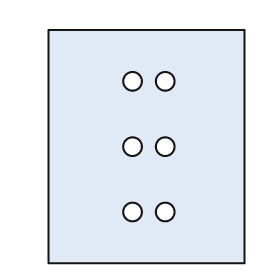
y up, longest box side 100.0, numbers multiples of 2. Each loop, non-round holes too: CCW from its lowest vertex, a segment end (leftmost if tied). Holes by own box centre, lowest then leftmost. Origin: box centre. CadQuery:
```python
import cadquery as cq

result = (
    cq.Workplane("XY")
    .moveTo(-42.0, -50.0)
    .lineTo(42.0, -50.0)
    .lineTo(42.0, 50.0)
    .lineTo(-42.0, 50.0)
    .close()
    .moveTo(-6.0, -28.0)
    .circle(4.0)
    .moveTo(8.0, -28.0)
    .circle(4.0)
    .moveTo(-6.0, 0.0)
    .circle(4.0)
    .moveTo(8.0, 0.0)
    .circle(4.0)
    .moveTo(-6.0, 28.0)
    .circle(4.0)
    .moveTo(8.0, 28.0)
    .circle(4.0)
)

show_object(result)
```